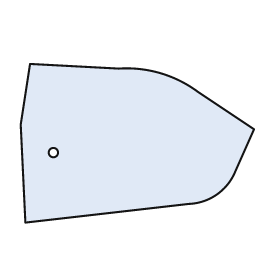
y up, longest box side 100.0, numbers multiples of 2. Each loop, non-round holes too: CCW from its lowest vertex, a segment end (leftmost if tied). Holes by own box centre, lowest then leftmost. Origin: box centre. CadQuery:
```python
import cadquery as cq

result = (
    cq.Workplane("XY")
    .moveTo(-48.0, -34.0)
    .lineTo(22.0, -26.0)
    .threePointArc((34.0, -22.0), (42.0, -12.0))
    .lineTo(50.0, 6.0)
    .lineTo(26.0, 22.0)
    .threePointArc((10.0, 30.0), (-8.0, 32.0))
    .lineTo(-46.0, 34.0)
    .lineTo(-50.0, 8.0)
    .close()
    .moveTo(-36.0, -4.0)
    .circle(2.0)
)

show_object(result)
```